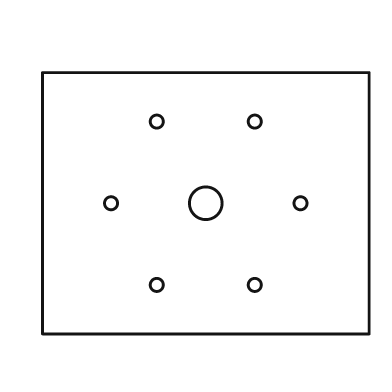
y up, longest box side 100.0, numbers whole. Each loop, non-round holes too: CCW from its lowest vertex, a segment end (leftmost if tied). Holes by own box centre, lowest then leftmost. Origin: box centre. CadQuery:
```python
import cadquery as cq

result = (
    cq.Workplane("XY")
    .moveTo(-50.0, -40.0)
    .lineTo(50.0, -40.0)
    .lineTo(50.0, 40.0)
    .lineTo(-50.0, 40.0)
    .close()
    .moveTo(-15.0, -25.0)
    .circle(2.0)
    .moveTo(15.0, -25.0)
    .circle(2.0)
    .moveTo(-29.0, 0.0)
    .circle(2.0)
    .moveTo(0.0, 0.0)
    .circle(5.0)
    .moveTo(29.0, 0.0)
    .circle(2.0)
    .moveTo(-15.0, 25.0)
    .circle(2.0)
    .moveTo(15.0, 25.0)
    .circle(2.0)
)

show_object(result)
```